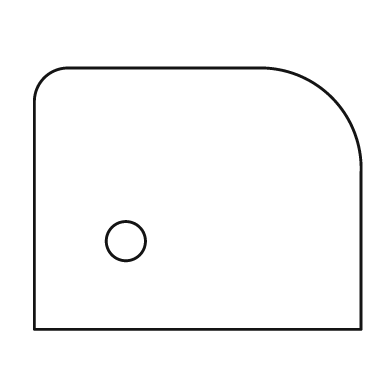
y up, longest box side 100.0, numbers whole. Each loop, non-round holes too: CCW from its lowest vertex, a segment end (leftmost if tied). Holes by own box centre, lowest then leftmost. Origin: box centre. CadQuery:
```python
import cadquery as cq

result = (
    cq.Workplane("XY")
    .moveTo(-50.0, -40.0)
    .lineTo(50.0, -40.0)
    .lineTo(50.0, 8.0)
    .threePointArc((41.0, 31.0), (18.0, 40.0))
    .lineTo(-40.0, 40.0)
    .threePointArc((-47.0, 37.0), (-50.0, 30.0))
    .close()
    .moveTo(-22.0, -13.0)
    .circle(6.0)
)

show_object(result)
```